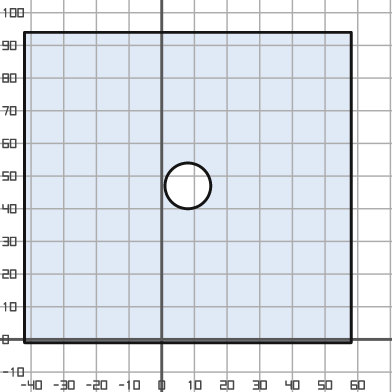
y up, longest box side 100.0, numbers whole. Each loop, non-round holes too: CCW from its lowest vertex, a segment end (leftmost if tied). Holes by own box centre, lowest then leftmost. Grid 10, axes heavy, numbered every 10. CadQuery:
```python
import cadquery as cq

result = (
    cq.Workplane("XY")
    .moveTo(-42.0, -1.0)
    .lineTo(58.0, -1.0)
    .lineTo(58.0, 94.0)
    .lineTo(-42.0, 94.0)
    .close()
    .moveTo(8.0, 47.0)
    .circle(7.0)
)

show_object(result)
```